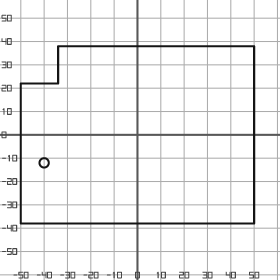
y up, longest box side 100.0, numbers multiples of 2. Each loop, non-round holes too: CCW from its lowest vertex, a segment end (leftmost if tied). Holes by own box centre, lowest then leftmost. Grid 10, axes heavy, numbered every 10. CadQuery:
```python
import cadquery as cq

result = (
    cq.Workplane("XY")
    .moveTo(-50.0, -38.0)
    .lineTo(50.0, -38.0)
    .lineTo(50.0, 38.0)
    .lineTo(-34.0, 38.0)
    .lineTo(-34.0, 22.0)
    .lineTo(-50.0, 22.0)
    .close()
    .moveTo(-40.0, -12.0)
    .circle(2.0)
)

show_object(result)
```